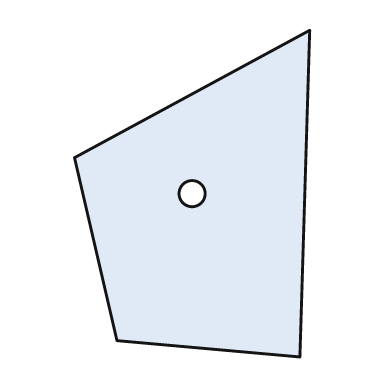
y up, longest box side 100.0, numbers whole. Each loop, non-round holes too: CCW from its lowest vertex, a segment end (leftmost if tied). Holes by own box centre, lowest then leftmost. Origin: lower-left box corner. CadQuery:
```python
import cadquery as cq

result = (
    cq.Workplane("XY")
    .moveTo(69.0, 0.0)
    .lineTo(72.0, 100.0)
    .lineTo(0.0, 61.0)
    .lineTo(13.0, 5.0)
    .close()
    .moveTo(36.0, 50.0)
    .circle(4.0)
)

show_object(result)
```